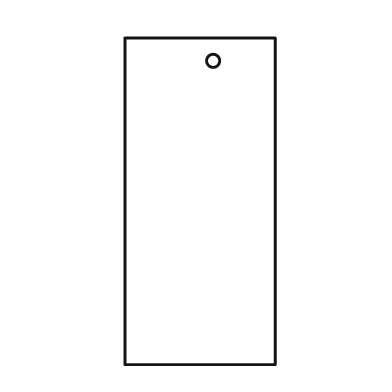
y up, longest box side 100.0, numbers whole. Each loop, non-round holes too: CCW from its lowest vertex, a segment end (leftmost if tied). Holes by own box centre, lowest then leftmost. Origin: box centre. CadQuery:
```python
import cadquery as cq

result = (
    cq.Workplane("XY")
    .moveTo(-23.0, -50.0)
    .lineTo(23.0, -50.0)
    .lineTo(23.0, 50.0)
    .lineTo(-23.0, 50.0)
    .close()
    .moveTo(4.0, 43.0)
    .circle(2.0)
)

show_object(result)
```